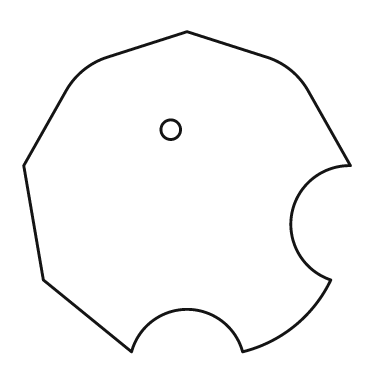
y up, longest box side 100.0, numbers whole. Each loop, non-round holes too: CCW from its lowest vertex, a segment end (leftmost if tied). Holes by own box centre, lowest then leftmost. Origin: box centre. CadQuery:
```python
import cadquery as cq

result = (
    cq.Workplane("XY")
    .moveTo(-17.0, -49.0)
    .threePointArc((0.0, -36.0), (17.0, -49.0))
    .threePointArc((33.0, -41.0), (44.0, -27.0))
    .threePointArc((32.0, -7.0), (50.0, 8.0))
    .lineTo(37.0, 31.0)
    .threePointArc((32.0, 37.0), (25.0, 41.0))
    .lineTo(0.0, 49.0)
    .lineTo(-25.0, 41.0)
    .threePointArc((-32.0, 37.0), (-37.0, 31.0))
    .lineTo(-50.0, 8.0)
    .lineTo(-44.0, -27.0)
    .close()
    .moveTo(-5.0, 19.0)
    .circle(3.0)
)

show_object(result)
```